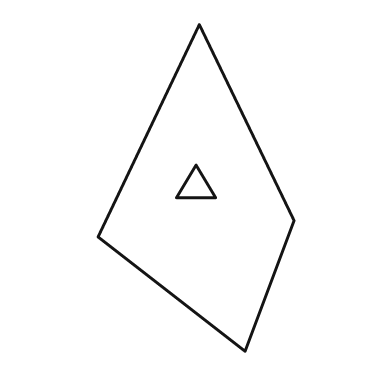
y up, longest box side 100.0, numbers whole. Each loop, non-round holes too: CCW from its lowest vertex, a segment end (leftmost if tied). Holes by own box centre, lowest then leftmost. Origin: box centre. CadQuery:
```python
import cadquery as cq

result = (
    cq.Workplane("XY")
    .moveTo(15.0, -50.0)
    .lineTo(30.0, -10.0)
    .lineTo(1.0, 50.0)
    .lineTo(-30.0, -15.0)
    .close()
    .moveTo(-6.0, -3.0)
    .lineTo(6.0, -3.0)
    .lineTo(0.0, 7.0)
    .close()
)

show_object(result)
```